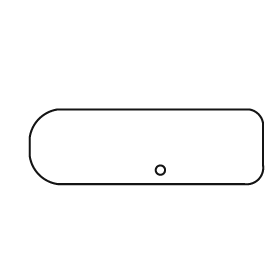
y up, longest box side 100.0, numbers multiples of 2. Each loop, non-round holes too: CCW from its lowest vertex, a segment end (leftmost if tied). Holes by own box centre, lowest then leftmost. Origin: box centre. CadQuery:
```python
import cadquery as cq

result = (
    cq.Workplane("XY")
    .moveTo(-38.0, -16.0)
    .lineTo(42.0, -16.0)
    .threePointArc((48.0, -14.0), (50.0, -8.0))
    .lineTo(50.0, 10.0)
    .threePointArc((48.0, 14.0), (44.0, 16.0))
    .lineTo(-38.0, 16.0)
    .threePointArc((-46.0, 12.0), (-50.0, 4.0))
    .lineTo(-50.0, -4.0)
    .threePointArc((-46.0, -12.0), (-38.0, -16.0))
    .close()
    .moveTo(6.0, -10.0)
    .circle(2.0)
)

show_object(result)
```